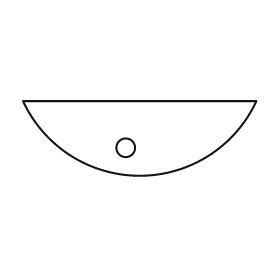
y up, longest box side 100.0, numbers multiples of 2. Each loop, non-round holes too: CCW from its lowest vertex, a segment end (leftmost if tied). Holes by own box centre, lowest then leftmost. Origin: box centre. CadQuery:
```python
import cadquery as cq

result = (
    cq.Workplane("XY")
    .moveTo(-50.0, 16.0)
    .threePointArc((0.0, -16.0), (50.0, 16.0))
    .close()
    .moveTo(-6.0, -4.0)
    .circle(4.0)
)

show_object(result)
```